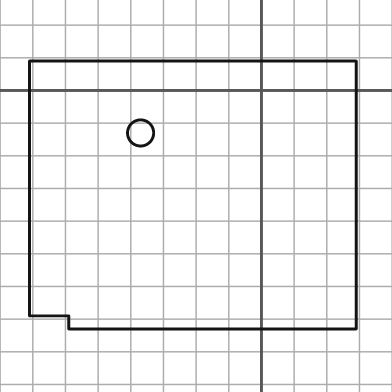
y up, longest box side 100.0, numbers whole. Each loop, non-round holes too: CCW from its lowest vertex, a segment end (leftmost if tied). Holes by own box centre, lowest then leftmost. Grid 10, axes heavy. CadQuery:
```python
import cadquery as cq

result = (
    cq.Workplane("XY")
    .moveTo(-59.0, -73.0)
    .lineTo(29.0, -73.0)
    .lineTo(29.0, 9.0)
    .lineTo(-71.0, 9.0)
    .lineTo(-71.0, -69.0)
    .lineTo(-59.0, -69.0)
    .close()
    .moveTo(-37.0, -13.0)
    .circle(4.0)
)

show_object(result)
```